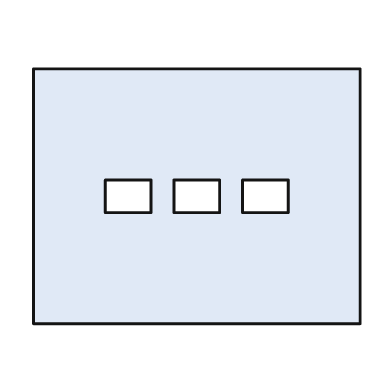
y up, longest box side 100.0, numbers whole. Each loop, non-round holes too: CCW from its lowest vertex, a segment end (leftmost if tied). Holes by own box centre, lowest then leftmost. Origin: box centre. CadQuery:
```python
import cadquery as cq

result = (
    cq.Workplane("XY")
    .moveTo(-50.0, -39.0)
    .lineTo(50.0, -39.0)
    .lineTo(50.0, 39.0)
    .lineTo(-50.0, 39.0)
    .close()
    .moveTo(-28.0, -5.0)
    .lineTo(-14.0, -5.0)
    .lineTo(-14.0, 5.0)
    .lineTo(-28.0, 5.0)
    .close()
    .moveTo(-7.0, -5.0)
    .lineTo(7.0, -5.0)
    .lineTo(7.0, 5.0)
    .lineTo(-7.0, 5.0)
    .close()
    .moveTo(14.0, -5.0)
    .lineTo(28.0, -5.0)
    .lineTo(28.0, 5.0)
    .lineTo(14.0, 5.0)
    .close()
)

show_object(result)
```